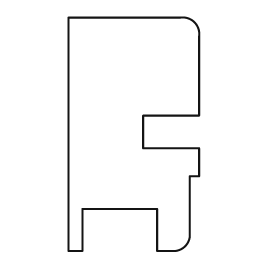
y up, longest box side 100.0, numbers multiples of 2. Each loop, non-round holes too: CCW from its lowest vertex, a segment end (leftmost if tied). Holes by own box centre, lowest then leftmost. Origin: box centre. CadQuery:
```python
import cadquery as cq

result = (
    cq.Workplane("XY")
    .moveTo(-28.0, -50.0)
    .lineTo(-22.0, -50.0)
    .lineTo(-22.0, -32.0)
    .lineTo(10.0, -32.0)
    .lineTo(10.0, -50.0)
    .lineTo(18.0, -50.0)
    .threePointArc((22.0, -48.0), (24.0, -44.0))
    .lineTo(24.0, -18.0)
    .lineTo(28.0, -18.0)
    .lineTo(28.0, -6.0)
    .lineTo(4.0, -6.0)
    .lineTo(4.0, 8.0)
    .lineTo(28.0, 8.0)
    .lineTo(28.0, 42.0)
    .threePointArc((26.0, 48.0), (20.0, 50.0))
    .lineTo(-28.0, 50.0)
    .close()
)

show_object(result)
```